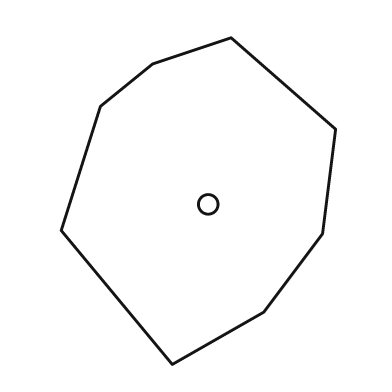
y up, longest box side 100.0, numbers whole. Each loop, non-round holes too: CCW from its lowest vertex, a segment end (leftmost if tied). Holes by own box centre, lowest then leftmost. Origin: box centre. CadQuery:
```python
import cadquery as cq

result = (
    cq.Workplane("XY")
    .moveTo(-8.0, -50.0)
    .lineTo(20.0, -34.0)
    .lineTo(38.0, -10.0)
    .lineTo(42.0, 22.0)
    .lineTo(10.0, 50.0)
    .lineTo(-14.0, 42.0)
    .lineTo(-30.0, 29.0)
    .lineTo(-42.0, -9.0)
    .close()
    .moveTo(3.0, -1.0)
    .circle(3.0)
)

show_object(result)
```